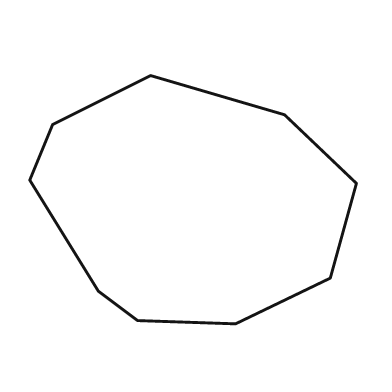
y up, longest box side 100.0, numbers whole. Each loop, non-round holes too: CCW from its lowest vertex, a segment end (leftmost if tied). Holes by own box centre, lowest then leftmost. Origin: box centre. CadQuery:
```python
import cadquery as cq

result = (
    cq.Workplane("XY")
    .moveTo(13.0, -38.0)
    .lineTo(42.0, -24.0)
    .lineTo(50.0, 5.0)
    .lineTo(28.0, 26.0)
    .lineTo(-13.0, 38.0)
    .lineTo(-43.0, 23.0)
    .lineTo(-50.0, 6.0)
    .lineTo(-29.0, -28.0)
    .lineTo(-17.0, -37.0)
    .close()
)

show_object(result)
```